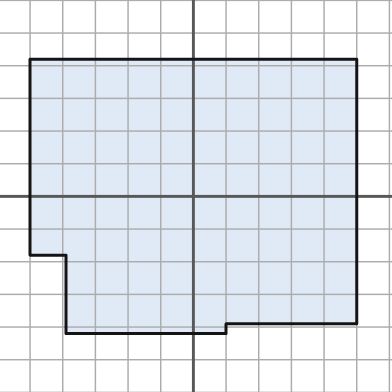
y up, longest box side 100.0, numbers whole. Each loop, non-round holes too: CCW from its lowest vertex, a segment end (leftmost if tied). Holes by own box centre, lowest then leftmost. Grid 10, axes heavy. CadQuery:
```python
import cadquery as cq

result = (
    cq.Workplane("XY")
    .moveTo(-39.0, -42.0)
    .lineTo(10.0, -42.0)
    .lineTo(10.0, -39.0)
    .lineTo(50.0, -39.0)
    .lineTo(50.0, 42.0)
    .lineTo(-50.0, 42.0)
    .lineTo(-50.0, -18.0)
    .lineTo(-39.0, -18.0)
    .close()
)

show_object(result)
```